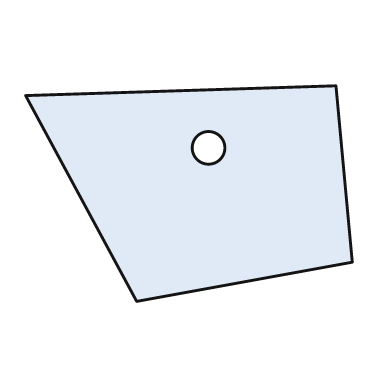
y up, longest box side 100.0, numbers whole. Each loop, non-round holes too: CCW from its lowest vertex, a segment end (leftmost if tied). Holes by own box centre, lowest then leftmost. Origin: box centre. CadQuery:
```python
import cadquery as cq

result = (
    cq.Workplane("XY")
    .moveTo(-16.0, -33.0)
    .lineTo(50.0, -21.0)
    .lineTo(45.0, 33.0)
    .lineTo(-50.0, 30.0)
    .close()
    .moveTo(6.0, 14.0)
    .circle(5.0)
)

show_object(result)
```